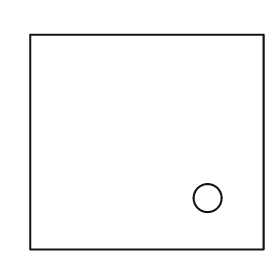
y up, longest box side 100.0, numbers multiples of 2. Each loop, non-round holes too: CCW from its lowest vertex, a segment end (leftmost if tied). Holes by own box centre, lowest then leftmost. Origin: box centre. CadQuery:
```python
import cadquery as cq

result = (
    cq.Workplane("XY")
    .moveTo(-50.0, -46.0)
    .lineTo(50.0, -46.0)
    .lineTo(50.0, 46.0)
    .lineTo(-50.0, 46.0)
    .close()
    .moveTo(26.0, -24.0)
    .circle(6.0)
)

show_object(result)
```